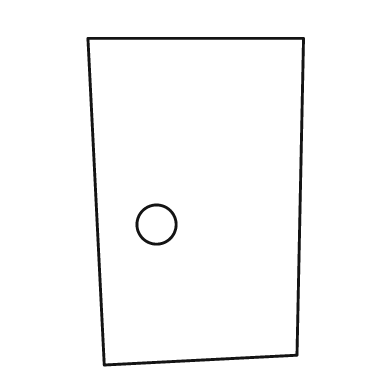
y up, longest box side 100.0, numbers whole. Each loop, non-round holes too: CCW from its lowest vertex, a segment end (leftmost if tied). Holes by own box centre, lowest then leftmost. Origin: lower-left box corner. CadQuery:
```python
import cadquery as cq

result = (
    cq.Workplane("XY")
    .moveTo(5.0, 0.0)
    .lineTo(64.0, 3.0)
    .lineTo(66.0, 100.0)
    .lineTo(0.0, 100.0)
    .close()
    .moveTo(21.0, 43.0)
    .circle(6.0)
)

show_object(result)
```